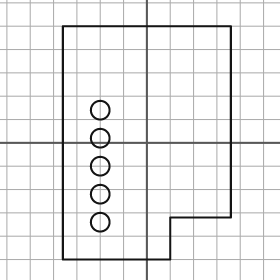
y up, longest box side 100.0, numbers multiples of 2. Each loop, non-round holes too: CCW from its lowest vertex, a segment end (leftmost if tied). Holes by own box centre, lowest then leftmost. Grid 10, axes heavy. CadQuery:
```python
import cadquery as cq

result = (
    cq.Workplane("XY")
    .moveTo(-36.0, -50.0)
    .lineTo(10.0, -50.0)
    .lineTo(10.0, -32.0)
    .lineTo(36.0, -32.0)
    .lineTo(36.0, 50.0)
    .lineTo(-36.0, 50.0)
    .close()
    .moveTo(-20.0, -34.0)
    .circle(4.0)
    .moveTo(-20.0, -22.0)
    .circle(4.0)
    .moveTo(-20.0, -10.0)
    .circle(4.0)
    .moveTo(-20.0, 2.0)
    .circle(4.0)
    .moveTo(-20.0, 14.0)
    .circle(4.0)
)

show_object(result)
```